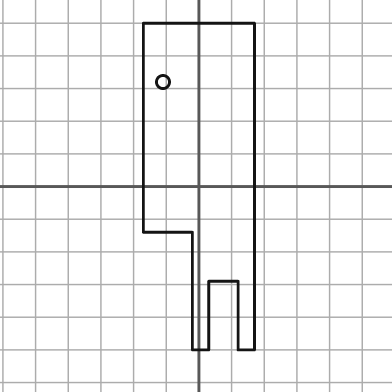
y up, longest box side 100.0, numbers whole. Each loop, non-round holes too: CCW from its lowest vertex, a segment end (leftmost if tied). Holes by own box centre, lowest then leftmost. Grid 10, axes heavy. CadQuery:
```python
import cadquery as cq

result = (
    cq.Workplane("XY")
    .moveTo(-2.0, -50.0)
    .lineTo(3.0, -50.0)
    .lineTo(3.0, -29.0)
    .lineTo(12.0, -29.0)
    .lineTo(12.0, -50.0)
    .lineTo(17.0, -50.0)
    .lineTo(17.0, 50.0)
    .lineTo(-17.0, 50.0)
    .lineTo(-17.0, -14.0)
    .lineTo(-2.0, -14.0)
    .close()
    .moveTo(-11.0, 32.0)
    .circle(2.0)
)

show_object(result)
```